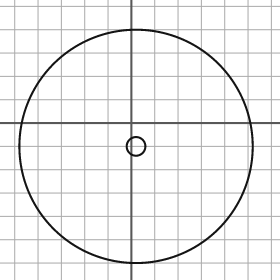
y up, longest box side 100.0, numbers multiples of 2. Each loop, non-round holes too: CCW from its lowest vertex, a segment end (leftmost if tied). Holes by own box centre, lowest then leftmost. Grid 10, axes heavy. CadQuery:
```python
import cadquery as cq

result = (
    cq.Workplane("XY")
    .moveTo(2.0, -10.0)
    .circle(50.0)
    .moveTo(2.0, -10.0)
    .circle(4.0)
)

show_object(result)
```